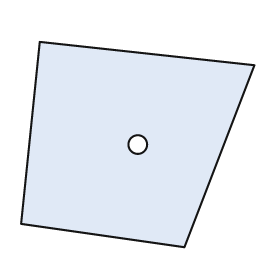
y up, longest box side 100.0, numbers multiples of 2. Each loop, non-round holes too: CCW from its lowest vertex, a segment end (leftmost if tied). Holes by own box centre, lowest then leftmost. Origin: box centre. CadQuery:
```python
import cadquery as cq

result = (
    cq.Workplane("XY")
    .moveTo(20.0, -44.0)
    .lineTo(50.0, 34.0)
    .lineTo(-42.0, 44.0)
    .lineTo(-50.0, -34.0)
    .close()
    .moveTo(0.0, 0.0)
    .circle(4.0)
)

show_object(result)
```